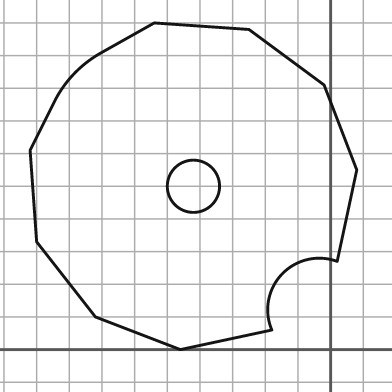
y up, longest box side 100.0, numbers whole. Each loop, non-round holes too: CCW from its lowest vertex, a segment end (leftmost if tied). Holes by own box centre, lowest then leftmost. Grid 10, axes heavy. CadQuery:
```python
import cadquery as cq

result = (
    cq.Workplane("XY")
    .moveTo(-46.0, 0.0)
    .lineTo(-18.0, 6.0)
    .threePointArc((-15.0, 23.0), (2.0, 27.0))
    .lineTo(8.0, 55.0)
    .lineTo(-2.0, 81.0)
    .lineTo(-25.0, 98.0)
    .lineTo(-54.0, 100.0)
    .lineTo(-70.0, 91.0)
    .threePointArc((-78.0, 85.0), (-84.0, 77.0))
    .lineTo(-92.0, 61.0)
    .lineTo(-90.0, 33.0)
    .lineTo(-72.0, 10.0)
    .close()
    .moveTo(-42.0, 50.0)
    .circle(8.0)
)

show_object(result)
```